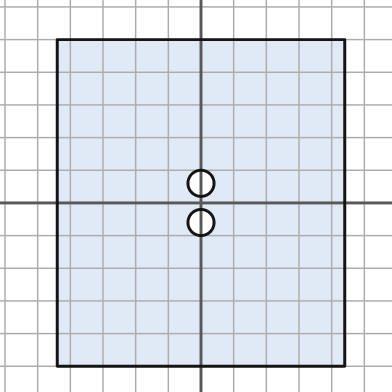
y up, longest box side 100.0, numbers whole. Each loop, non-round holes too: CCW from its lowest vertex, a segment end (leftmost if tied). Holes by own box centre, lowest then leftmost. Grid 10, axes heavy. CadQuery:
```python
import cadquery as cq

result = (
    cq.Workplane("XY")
    .moveTo(-44.0, -50.0)
    .lineTo(44.0, -50.0)
    .lineTo(44.0, 50.0)
    .lineTo(-44.0, 50.0)
    .close()
    .moveTo(0.0, -6.0)
    .circle(4.0)
    .moveTo(0.0, 6.0)
    .circle(4.0)
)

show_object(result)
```